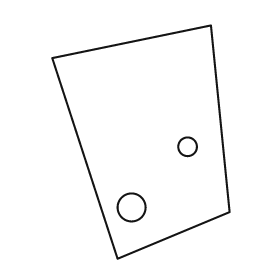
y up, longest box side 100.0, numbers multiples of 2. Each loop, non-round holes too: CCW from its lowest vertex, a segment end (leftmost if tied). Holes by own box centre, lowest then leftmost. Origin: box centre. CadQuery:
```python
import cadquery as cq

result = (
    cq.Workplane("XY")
    .moveTo(-10.0, -50.0)
    .lineTo(38.0, -30.0)
    .lineTo(30.0, 50.0)
    .lineTo(-38.0, 36.0)
    .close()
    .moveTo(-4.0, -28.0)
    .circle(6.0)
    .moveTo(20.0, -2.0)
    .circle(4.0)
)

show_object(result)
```